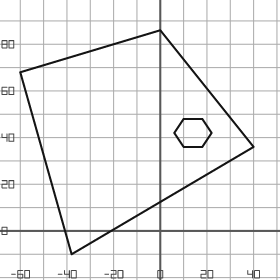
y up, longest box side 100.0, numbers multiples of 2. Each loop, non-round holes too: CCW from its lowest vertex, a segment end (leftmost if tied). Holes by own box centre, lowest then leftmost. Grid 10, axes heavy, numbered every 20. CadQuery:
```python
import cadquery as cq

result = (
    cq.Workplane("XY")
    .moveTo(-38.0, -10.0)
    .lineTo(40.0, 36.0)
    .lineTo(0.0, 86.0)
    .lineTo(-60.0, 68.0)
    .close()
    .moveTo(10.0, 36.0)
    .lineTo(18.0, 36.0)
    .lineTo(22.0, 42.0)
    .lineTo(18.0, 48.0)
    .lineTo(10.0, 48.0)
    .lineTo(6.0, 42.0)
    .close()
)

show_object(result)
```